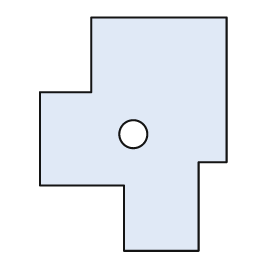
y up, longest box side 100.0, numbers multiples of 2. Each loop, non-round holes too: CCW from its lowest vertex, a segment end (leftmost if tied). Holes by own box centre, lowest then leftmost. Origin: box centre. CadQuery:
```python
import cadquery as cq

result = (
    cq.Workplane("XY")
    .moveTo(-4.0, -50.0)
    .lineTo(28.0, -50.0)
    .lineTo(28.0, -12.0)
    .lineTo(40.0, -12.0)
    .lineTo(40.0, 50.0)
    .lineTo(-18.0, 50.0)
    .lineTo(-18.0, 18.0)
    .lineTo(-40.0, 18.0)
    .lineTo(-40.0, -22.0)
    .lineTo(-4.0, -22.0)
    .close()
    .moveTo(0.0, 0.0)
    .circle(6.0)
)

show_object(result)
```